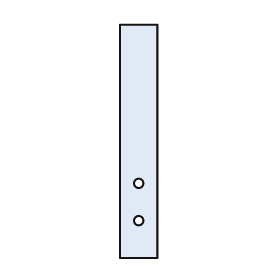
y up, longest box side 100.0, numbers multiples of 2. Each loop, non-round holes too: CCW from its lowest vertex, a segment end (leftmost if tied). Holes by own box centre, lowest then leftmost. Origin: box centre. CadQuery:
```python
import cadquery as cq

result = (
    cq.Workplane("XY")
    .moveTo(-8.0, -50.0)
    .lineTo(8.0, -50.0)
    .lineTo(8.0, 50.0)
    .lineTo(-8.0, 50.0)
    .close()
    .moveTo(0.0, -34.0)
    .circle(2.0)
    .moveTo(0.0, -18.0)
    .circle(2.0)
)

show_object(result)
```